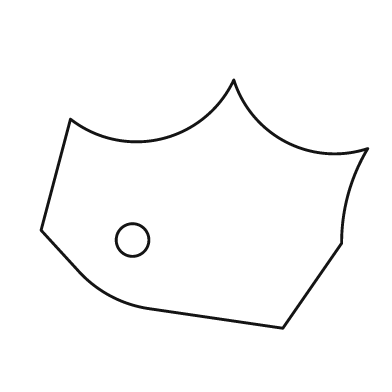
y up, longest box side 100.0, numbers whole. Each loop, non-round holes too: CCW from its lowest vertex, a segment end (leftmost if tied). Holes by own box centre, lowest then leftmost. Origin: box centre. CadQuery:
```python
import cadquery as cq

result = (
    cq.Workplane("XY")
    .moveTo(24.0, -38.0)
    .lineTo(42.0, -12.0)
    .threePointArc((44.0, 3.0), (50.0, 17.0))
    .threePointArc((25.0, 19.0), (9.0, 38.0))
    .threePointArc((-13.0, 20.0), (-41.0, 26.0))
    .lineTo(-50.0, -8.0)
    .lineTo(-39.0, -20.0)
    .threePointArc((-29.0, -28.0), (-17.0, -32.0))
    .close()
    .moveTo(-22.0, -11.0)
    .circle(5.0)
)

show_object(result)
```